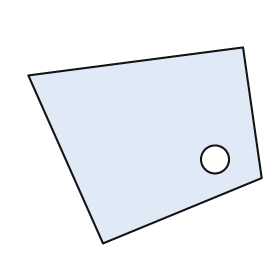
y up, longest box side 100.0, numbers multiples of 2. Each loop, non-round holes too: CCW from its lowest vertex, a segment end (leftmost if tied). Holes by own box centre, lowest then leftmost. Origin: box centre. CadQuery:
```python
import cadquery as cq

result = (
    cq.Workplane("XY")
    .moveTo(-18.0, -42.0)
    .lineTo(50.0, -14.0)
    .lineTo(42.0, 42.0)
    .lineTo(-50.0, 30.0)
    .close()
    .moveTo(30.0, -6.0)
    .circle(6.0)
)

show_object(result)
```